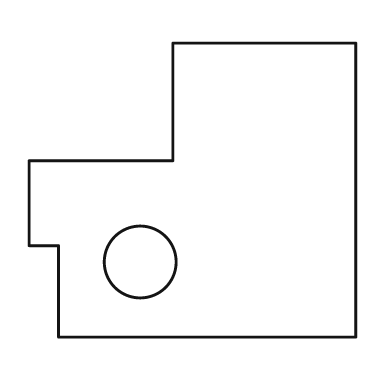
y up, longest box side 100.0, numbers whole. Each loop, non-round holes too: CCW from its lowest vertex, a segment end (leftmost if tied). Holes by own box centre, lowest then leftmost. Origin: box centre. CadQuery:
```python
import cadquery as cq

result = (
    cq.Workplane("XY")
    .moveTo(-41.0, -45.0)
    .lineTo(50.0, -45.0)
    .lineTo(50.0, 45.0)
    .lineTo(-6.0, 45.0)
    .lineTo(-6.0, 9.0)
    .lineTo(-50.0, 9.0)
    .lineTo(-50.0, -17.0)
    .lineTo(-41.0, -17.0)
    .close()
    .moveTo(-16.0, -22.0)
    .circle(11.0)
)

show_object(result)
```